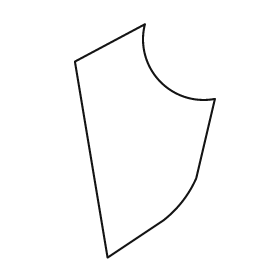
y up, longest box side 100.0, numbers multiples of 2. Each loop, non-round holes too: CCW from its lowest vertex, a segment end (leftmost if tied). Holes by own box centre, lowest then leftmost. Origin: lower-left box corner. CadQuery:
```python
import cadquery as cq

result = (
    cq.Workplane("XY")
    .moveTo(14.0, 0.0)
    .lineTo(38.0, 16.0)
    .threePointArc((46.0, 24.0), (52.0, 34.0))
    .lineTo(60.0, 68.0)
    .threePointArc((36.0, 76.0), (30.0, 100.0))
    .lineTo(0.0, 84.0)
    .close()
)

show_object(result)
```